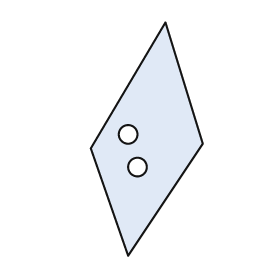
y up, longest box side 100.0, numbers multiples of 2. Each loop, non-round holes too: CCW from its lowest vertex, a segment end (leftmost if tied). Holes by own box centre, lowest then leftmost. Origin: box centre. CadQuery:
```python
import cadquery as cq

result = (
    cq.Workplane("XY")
    .moveTo(-8.0, -50.0)
    .lineTo(24.0, -2.0)
    .lineTo(8.0, 50.0)
    .lineTo(-24.0, -4.0)
    .close()
    .moveTo(-4.0, -12.0)
    .circle(4.0)
    .moveTo(-8.0, 2.0)
    .circle(4.0)
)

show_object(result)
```